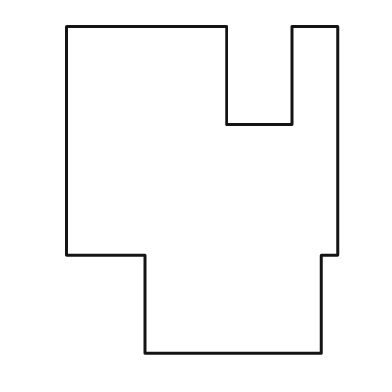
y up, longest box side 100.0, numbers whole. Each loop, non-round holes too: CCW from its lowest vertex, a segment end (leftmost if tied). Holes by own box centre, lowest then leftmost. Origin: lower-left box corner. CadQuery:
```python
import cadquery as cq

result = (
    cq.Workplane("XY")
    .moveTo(24.0, 0.0)
    .lineTo(78.0, 0.0)
    .lineTo(78.0, 30.0)
    .lineTo(83.0, 30.0)
    .lineTo(83.0, 100.0)
    .lineTo(69.0, 100.0)
    .lineTo(69.0, 70.0)
    .lineTo(49.0, 70.0)
    .lineTo(49.0, 100.0)
    .lineTo(0.0, 100.0)
    .lineTo(0.0, 30.0)
    .lineTo(24.0, 30.0)
    .close()
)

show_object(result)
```